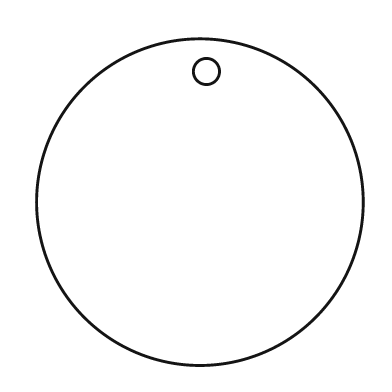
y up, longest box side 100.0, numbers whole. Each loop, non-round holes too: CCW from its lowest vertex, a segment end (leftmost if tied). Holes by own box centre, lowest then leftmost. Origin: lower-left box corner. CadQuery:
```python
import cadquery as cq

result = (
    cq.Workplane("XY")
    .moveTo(50.0, 50.0)
    .circle(50.0)
    .moveTo(52.0, 90.0)
    .circle(4.0)
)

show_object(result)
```